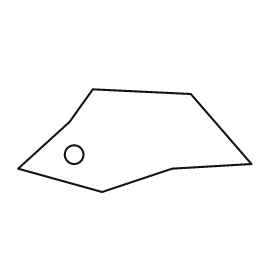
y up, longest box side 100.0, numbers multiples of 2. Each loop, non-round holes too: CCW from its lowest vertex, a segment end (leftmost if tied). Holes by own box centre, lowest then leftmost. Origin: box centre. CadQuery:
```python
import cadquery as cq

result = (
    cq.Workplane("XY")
    .moveTo(-14.0, -22.0)
    .lineTo(16.0, -12.0)
    .lineTo(50.0, -10.0)
    .lineTo(24.0, 20.0)
    .lineTo(-18.0, 22.0)
    .lineTo(-28.0, 8.0)
    .lineTo(-50.0, -12.0)
    .close()
    .moveTo(-26.0, -6.0)
    .circle(4.0)
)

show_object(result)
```